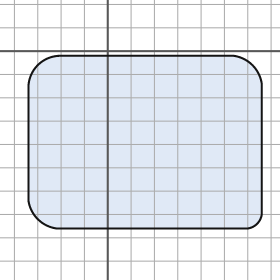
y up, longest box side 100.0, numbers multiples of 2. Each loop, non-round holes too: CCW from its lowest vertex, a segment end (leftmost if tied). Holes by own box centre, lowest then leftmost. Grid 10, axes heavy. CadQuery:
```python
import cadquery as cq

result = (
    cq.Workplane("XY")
    .moveTo(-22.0, -76.0)
    .lineTo(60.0, -76.0)
    .threePointArc((64.0, -74.0), (66.0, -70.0))
    .lineTo(66.0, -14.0)
    .threePointArc((62.0, -6.0), (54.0, -2.0))
    .lineTo(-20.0, -2.0)
    .threePointArc((-30.0, -6.0), (-34.0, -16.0))
    .lineTo(-34.0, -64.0)
    .threePointArc((-30.0, -72.0), (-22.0, -76.0))
    .close()
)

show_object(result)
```